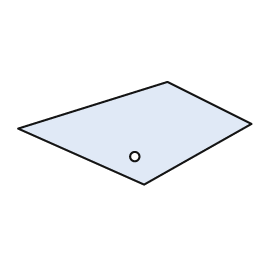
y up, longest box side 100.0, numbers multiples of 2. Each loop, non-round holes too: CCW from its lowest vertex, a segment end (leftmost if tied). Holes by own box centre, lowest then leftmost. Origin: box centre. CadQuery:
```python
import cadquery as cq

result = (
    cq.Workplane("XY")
    .moveTo(4.0, -22.0)
    .lineTo(50.0, 4.0)
    .lineTo(14.0, 22.0)
    .lineTo(-50.0, 2.0)
    .close()
    .moveTo(0.0, -10.0)
    .circle(2.0)
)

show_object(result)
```